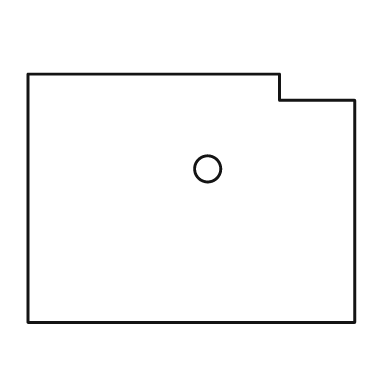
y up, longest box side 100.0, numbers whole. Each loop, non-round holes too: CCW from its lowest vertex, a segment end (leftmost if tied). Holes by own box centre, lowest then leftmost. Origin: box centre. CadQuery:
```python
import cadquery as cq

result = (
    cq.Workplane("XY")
    .moveTo(-50.0, -38.0)
    .lineTo(50.0, -38.0)
    .lineTo(50.0, 30.0)
    .lineTo(27.0, 30.0)
    .lineTo(27.0, 38.0)
    .lineTo(-50.0, 38.0)
    .close()
    .moveTo(5.0, 9.0)
    .circle(4.0)
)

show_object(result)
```